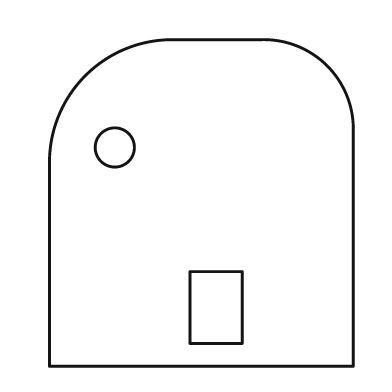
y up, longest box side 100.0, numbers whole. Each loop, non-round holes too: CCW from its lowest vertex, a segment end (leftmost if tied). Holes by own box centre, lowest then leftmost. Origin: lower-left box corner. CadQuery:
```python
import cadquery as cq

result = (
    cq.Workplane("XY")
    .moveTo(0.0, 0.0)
    .lineTo(93.0, 0.0)
    .lineTo(93.0, 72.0)
    .threePointArc((85.0, 92.0), (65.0, 100.0))
    .lineTo(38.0, 100.0)
    .threePointArc((11.0, 89.0), (0.0, 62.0))
    .close()
    .moveTo(43.0, 7.0)
    .lineTo(59.0, 7.0)
    .lineTo(59.0, 29.0)
    .lineTo(43.0, 29.0)
    .close()
    .moveTo(20.0, 67.0)
    .circle(6.0)
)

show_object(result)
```